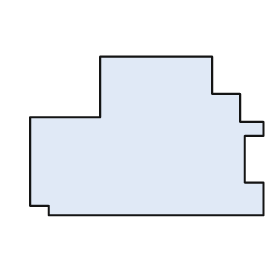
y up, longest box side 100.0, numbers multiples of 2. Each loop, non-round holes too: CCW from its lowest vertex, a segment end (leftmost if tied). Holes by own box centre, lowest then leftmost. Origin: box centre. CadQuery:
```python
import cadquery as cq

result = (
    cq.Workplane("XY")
    .moveTo(-42.0, -34.0)
    .lineTo(50.0, -34.0)
    .lineTo(50.0, -20.0)
    .lineTo(42.0, -20.0)
    .lineTo(42.0, 0.0)
    .lineTo(50.0, 0.0)
    .lineTo(50.0, 6.0)
    .lineTo(40.0, 6.0)
    .lineTo(40.0, 18.0)
    .lineTo(28.0, 18.0)
    .lineTo(28.0, 34.0)
    .lineTo(-20.0, 34.0)
    .lineTo(-20.0, 8.0)
    .lineTo(-50.0, 8.0)
    .lineTo(-50.0, -30.0)
    .lineTo(-42.0, -30.0)
    .close()
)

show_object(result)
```